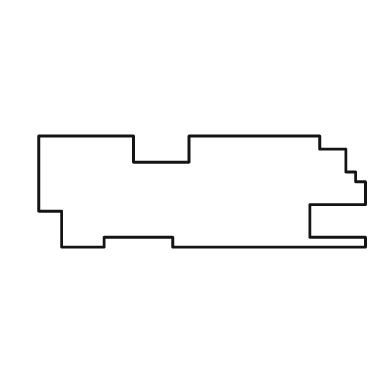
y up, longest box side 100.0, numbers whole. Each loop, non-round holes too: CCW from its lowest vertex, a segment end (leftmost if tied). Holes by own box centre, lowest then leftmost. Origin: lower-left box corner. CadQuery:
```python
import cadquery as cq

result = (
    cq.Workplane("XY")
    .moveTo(7.0, 0.0)
    .lineTo(20.0, 0.0)
    .lineTo(20.0, 3.0)
    .lineTo(41.0, 3.0)
    .lineTo(41.0, 0.0)
    .lineTo(100.0, 0.0)
    .lineTo(100.0, 3.0)
    .lineTo(83.0, 3.0)
    .lineTo(83.0, 13.0)
    .lineTo(100.0, 13.0)
    .lineTo(100.0, 20.0)
    .lineTo(97.0, 20.0)
    .lineTo(97.0, 23.0)
    .lineTo(94.0, 23.0)
    .lineTo(94.0, 30.0)
    .lineTo(86.0, 30.0)
    .lineTo(86.0, 34.0)
    .lineTo(46.0, 34.0)
    .lineTo(46.0, 26.0)
    .lineTo(29.0, 26.0)
    .lineTo(29.0, 34.0)
    .lineTo(0.0, 34.0)
    .lineTo(0.0, 11.0)
    .lineTo(7.0, 11.0)
    .close()
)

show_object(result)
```